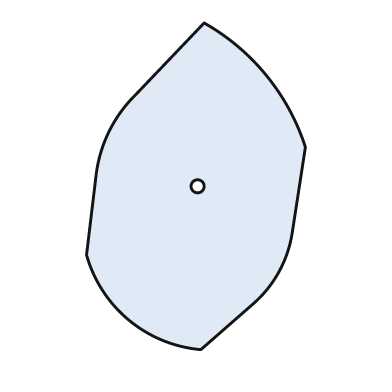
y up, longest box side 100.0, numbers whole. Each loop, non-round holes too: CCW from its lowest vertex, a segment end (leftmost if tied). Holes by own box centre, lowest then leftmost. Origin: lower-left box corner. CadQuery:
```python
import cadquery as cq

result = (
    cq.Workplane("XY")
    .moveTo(35.0, 0.0)
    .lineTo(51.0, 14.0)
    .threePointArc((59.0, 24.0), (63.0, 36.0))
    .lineTo(67.0, 62.0)
    .threePointArc((55.0, 84.0), (36.0, 100.0))
    .lineTo(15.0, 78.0)
    .threePointArc((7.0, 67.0), (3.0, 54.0))
    .lineTo(0.0, 29.0)
    .threePointArc((13.0, 9.0), (35.0, 0.0))
    .close()
    .moveTo(34.0, 50.0)
    .circle(2.0)
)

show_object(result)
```